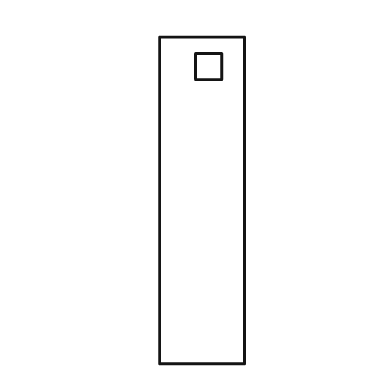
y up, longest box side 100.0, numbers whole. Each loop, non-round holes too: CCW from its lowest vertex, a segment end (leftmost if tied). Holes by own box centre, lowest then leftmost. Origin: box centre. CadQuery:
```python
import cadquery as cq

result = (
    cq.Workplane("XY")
    .moveTo(-13.0, -50.0)
    .lineTo(13.0, -50.0)
    .lineTo(13.0, 50.0)
    .lineTo(-13.0, 50.0)
    .close()
    .moveTo(-2.0, 37.0)
    .lineTo(6.0, 37.0)
    .lineTo(6.0, 45.0)
    .lineTo(-2.0, 45.0)
    .close()
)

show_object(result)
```